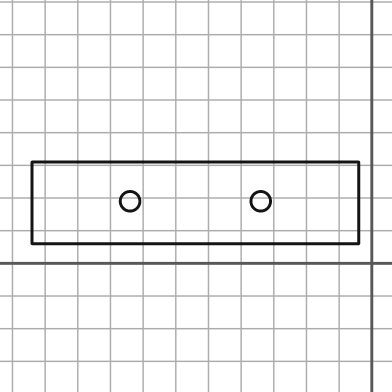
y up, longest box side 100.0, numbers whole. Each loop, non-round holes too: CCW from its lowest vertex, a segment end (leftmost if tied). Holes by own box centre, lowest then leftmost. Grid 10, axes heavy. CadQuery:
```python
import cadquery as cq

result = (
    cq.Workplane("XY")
    .moveTo(-104.0, 6.0)
    .lineTo(-4.0, 6.0)
    .lineTo(-4.0, 31.0)
    .lineTo(-104.0, 31.0)
    .close()
    .moveTo(-74.0, 19.0)
    .circle(3.0)
    .moveTo(-34.0, 19.0)
    .circle(3.0)
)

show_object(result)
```